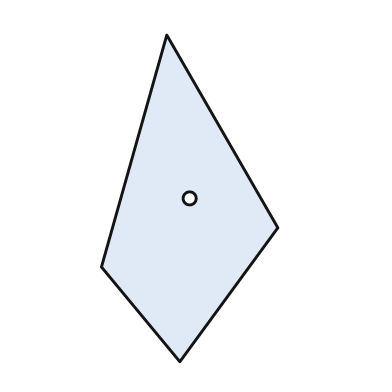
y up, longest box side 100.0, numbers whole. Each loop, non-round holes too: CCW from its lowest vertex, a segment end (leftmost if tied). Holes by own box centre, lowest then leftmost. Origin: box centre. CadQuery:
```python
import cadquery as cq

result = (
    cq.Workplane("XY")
    .moveTo(-3.0, -50.0)
    .lineTo(27.0, -9.0)
    .lineTo(-7.0, 50.0)
    .lineTo(-27.0, -21.0)
    .close()
    .moveTo(0.0, 0.0)
    .circle(2.0)
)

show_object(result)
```